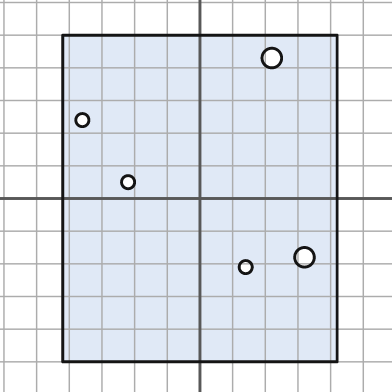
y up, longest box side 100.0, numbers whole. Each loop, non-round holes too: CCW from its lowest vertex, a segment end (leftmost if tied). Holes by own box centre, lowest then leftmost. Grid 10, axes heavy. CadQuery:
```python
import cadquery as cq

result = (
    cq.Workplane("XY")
    .moveTo(-42.0, -50.0)
    .lineTo(42.0, -50.0)
    .lineTo(42.0, 50.0)
    .lineTo(-42.0, 50.0)
    .close()
    .moveTo(14.0, -21.0)
    .circle(2.0)
    .moveTo(32.0, -18.0)
    .circle(3.0)
    .moveTo(-22.0, 5.0)
    .circle(2.0)
    .moveTo(-36.0, 24.0)
    .circle(2.0)
    .moveTo(22.0, 43.0)
    .circle(3.0)
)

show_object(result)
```